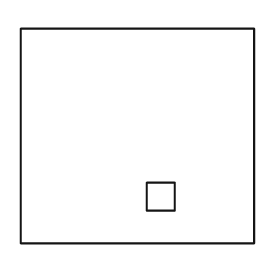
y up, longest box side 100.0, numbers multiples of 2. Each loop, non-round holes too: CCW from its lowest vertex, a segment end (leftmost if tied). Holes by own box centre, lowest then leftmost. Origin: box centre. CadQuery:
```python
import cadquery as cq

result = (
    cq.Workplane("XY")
    .moveTo(-50.0, -46.0)
    .lineTo(50.0, -46.0)
    .lineTo(50.0, 46.0)
    .lineTo(-50.0, 46.0)
    .close()
    .moveTo(4.0, -32.0)
    .lineTo(16.0, -32.0)
    .lineTo(16.0, -20.0)
    .lineTo(4.0, -20.0)
    .close()
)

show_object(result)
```